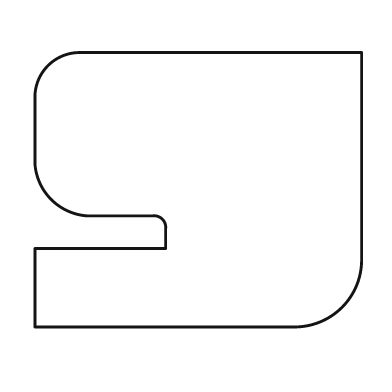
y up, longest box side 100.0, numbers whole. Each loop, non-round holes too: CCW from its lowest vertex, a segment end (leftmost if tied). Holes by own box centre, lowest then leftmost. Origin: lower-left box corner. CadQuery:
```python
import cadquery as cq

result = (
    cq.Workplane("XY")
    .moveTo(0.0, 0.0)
    .lineTo(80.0, 0.0)
    .threePointArc((94.0, 6.0), (100.0, 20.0))
    .lineTo(100.0, 84.0)
    .lineTo(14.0, 84.0)
    .threePointArc((4.0, 80.0), (0.0, 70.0))
    .lineTo(0.0, 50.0)
    .threePointArc((5.0, 39.0), (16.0, 34.0))
    .lineTo(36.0, 34.0)
    .threePointArc((39.0, 33.0), (40.0, 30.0))
    .lineTo(40.0, 24.0)
    .lineTo(0.0, 24.0)
    .close()
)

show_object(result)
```